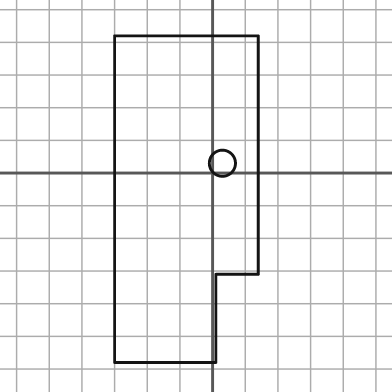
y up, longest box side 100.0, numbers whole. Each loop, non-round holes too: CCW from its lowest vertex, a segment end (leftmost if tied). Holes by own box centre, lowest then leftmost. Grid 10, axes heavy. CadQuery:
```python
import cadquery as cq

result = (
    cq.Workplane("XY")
    .moveTo(-30.0, -58.0)
    .lineTo(1.0, -58.0)
    .lineTo(1.0, -31.0)
    .lineTo(14.0, -31.0)
    .lineTo(14.0, 42.0)
    .lineTo(-30.0, 42.0)
    .close()
    .moveTo(3.0, 3.0)
    .circle(4.0)
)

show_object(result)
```